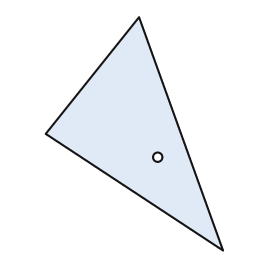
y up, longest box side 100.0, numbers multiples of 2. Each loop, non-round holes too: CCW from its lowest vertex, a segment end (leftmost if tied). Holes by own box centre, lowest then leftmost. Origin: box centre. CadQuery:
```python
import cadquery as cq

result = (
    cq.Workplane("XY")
    .moveTo(38.0, -50.0)
    .lineTo(2.0, 50.0)
    .lineTo(-38.0, 0.0)
    .close()
    .moveTo(10.0, -10.0)
    .circle(2.0)
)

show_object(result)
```